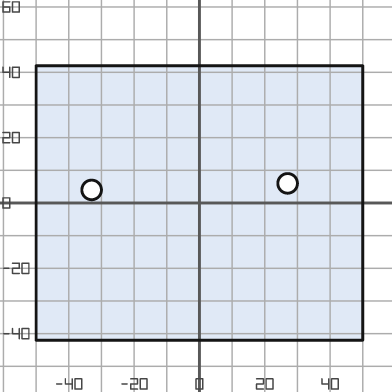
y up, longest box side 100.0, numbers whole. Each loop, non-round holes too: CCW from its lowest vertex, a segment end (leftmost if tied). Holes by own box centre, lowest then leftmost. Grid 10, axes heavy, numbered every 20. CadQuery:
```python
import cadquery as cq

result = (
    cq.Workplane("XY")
    .moveTo(-50.0, -42.0)
    .lineTo(50.0, -42.0)
    .lineTo(50.0, 42.0)
    .lineTo(-50.0, 42.0)
    .close()
    .moveTo(-33.0, 4.0)
    .circle(3.0)
    .moveTo(27.0, 6.0)
    .circle(3.0)
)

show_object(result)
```